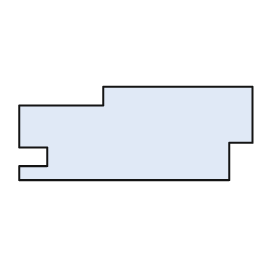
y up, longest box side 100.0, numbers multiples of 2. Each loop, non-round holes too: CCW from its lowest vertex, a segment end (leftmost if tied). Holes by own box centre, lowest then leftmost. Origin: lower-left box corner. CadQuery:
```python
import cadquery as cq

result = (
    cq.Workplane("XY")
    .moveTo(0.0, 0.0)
    .lineTo(90.0, 0.0)
    .lineTo(90.0, 16.0)
    .lineTo(100.0, 16.0)
    .lineTo(100.0, 40.0)
    .lineTo(36.0, 40.0)
    .lineTo(36.0, 32.0)
    .lineTo(0.0, 32.0)
    .lineTo(0.0, 14.0)
    .lineTo(12.0, 14.0)
    .lineTo(12.0, 6.0)
    .lineTo(0.0, 6.0)
    .close()
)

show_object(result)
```